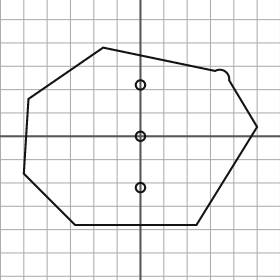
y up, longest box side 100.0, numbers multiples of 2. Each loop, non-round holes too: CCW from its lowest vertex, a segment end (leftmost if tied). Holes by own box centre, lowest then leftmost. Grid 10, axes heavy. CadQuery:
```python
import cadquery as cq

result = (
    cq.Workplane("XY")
    .moveTo(-28.0, -38.0)
    .lineTo(24.0, -38.0)
    .lineTo(50.0, 4.0)
    .lineTo(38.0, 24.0)
    .threePointArc((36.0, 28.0), (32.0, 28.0))
    .lineTo(-16.0, 38.0)
    .lineTo(-48.0, 16.0)
    .lineTo(-50.0, -16.0)
    .close()
    .moveTo(0.0, -22.0)
    .circle(2.0)
    .moveTo(0.0, 0.0)
    .circle(2.0)
    .moveTo(0.0, 22.0)
    .circle(2.0)
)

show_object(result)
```